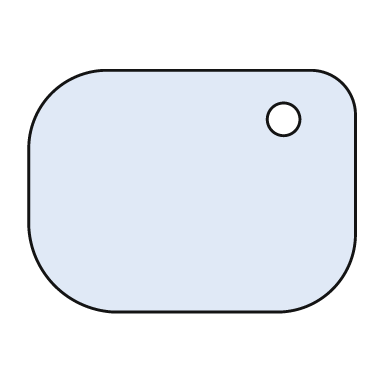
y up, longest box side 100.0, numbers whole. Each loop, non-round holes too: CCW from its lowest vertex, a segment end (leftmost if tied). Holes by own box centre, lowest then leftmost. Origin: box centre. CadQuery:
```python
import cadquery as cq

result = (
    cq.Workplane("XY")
    .moveTo(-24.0, -37.0)
    .lineTo(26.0, -37.0)
    .threePointArc((43.0, -30.0), (50.0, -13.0))
    .lineTo(50.0, 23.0)
    .threePointArc((46.0, 33.0), (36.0, 37.0))
    .lineTo(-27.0, 37.0)
    .threePointArc((-43.0, 30.0), (-50.0, 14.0))
    .lineTo(-50.0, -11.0)
    .threePointArc((-42.0, -29.0), (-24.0, -37.0))
    .close()
    .moveTo(28.0, 22.0)
    .circle(5.0)
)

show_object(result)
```